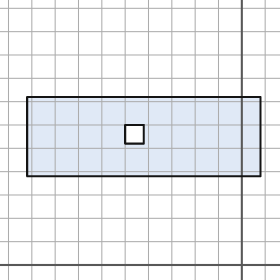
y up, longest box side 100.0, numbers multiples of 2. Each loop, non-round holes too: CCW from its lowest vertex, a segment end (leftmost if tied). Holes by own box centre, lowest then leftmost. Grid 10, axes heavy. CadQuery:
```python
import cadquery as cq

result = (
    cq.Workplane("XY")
    .moveTo(-92.0, 38.0)
    .lineTo(8.0, 38.0)
    .lineTo(8.0, 72.0)
    .lineTo(-92.0, 72.0)
    .close()
    .moveTo(-50.0, 52.0)
    .lineTo(-42.0, 52.0)
    .lineTo(-42.0, 60.0)
    .lineTo(-50.0, 60.0)
    .close()
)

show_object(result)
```